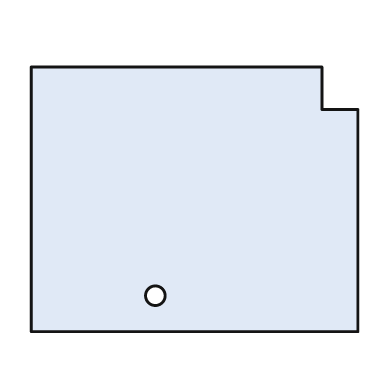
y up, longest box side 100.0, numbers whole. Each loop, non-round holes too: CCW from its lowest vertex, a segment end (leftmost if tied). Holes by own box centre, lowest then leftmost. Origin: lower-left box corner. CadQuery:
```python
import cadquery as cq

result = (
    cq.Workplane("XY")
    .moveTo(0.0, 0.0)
    .lineTo(100.0, 0.0)
    .lineTo(100.0, 68.0)
    .lineTo(89.0, 68.0)
    .lineTo(89.0, 81.0)
    .lineTo(0.0, 81.0)
    .close()
    .moveTo(38.0, 11.0)
    .circle(3.0)
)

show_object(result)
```